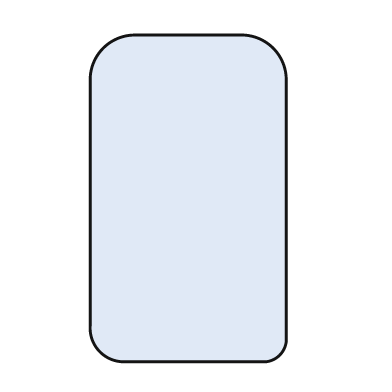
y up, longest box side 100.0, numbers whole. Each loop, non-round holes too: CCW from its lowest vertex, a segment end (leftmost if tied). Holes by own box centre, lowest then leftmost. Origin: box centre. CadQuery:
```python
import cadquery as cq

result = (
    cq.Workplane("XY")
    .moveTo(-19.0, -50.0)
    .lineTo(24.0, -50.0)
    .threePointArc((28.0, -48.0), (30.0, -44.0))
    .lineTo(30.0, 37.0)
    .threePointArc((26.0, 46.0), (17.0, 50.0))
    .lineTo(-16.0, 50.0)
    .threePointArc((-26.0, 46.0), (-30.0, 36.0))
    .lineTo(-30.0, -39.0)
    .threePointArc((-27.0, -47.0), (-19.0, -50.0))
    .close()
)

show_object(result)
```